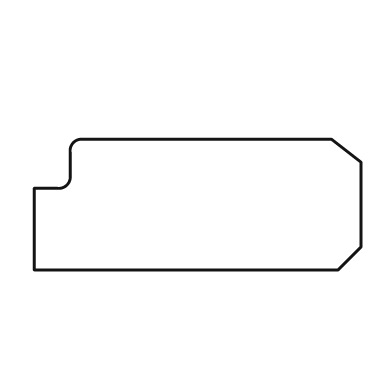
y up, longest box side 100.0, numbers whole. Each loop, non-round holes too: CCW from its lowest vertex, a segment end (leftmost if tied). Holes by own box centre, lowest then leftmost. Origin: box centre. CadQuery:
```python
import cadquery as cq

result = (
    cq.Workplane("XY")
    .moveTo(-50.0, -20.0)
    .lineTo(43.0, -20.0)
    .lineTo(50.0, -13.0)
    .lineTo(50.0, 13.0)
    .lineTo(41.0, 20.0)
    .lineTo(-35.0, 20.0)
    .threePointArc((-38.0, 19.0), (-39.0, 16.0))
    .lineTo(-39.0, 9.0)
    .threePointArc((-40.0, 6.0), (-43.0, 5.0))
    .lineTo(-50.0, 5.0)
    .close()
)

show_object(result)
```